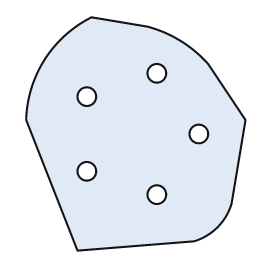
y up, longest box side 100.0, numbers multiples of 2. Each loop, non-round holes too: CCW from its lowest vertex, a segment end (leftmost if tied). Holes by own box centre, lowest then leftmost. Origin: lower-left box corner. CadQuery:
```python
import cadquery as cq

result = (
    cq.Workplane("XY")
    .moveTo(22.0, 0.0)
    .lineTo(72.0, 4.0)
    .threePointArc((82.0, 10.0), (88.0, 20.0))
    .lineTo(94.0, 56.0)
    .lineTo(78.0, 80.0)
    .threePointArc((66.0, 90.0), (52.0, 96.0))
    .lineTo(28.0, 100.0)
    .threePointArc((8.0, 82.0), (0.0, 56.0))
    .close()
    .moveTo(56.0, 24.0)
    .circle(4.0)
    .moveTo(26.0, 34.0)
    .circle(4.0)
    .moveTo(74.0, 50.0)
    .circle(4.0)
    .moveTo(26.0, 66.0)
    .circle(4.0)
    .moveTo(56.0, 76.0)
    .circle(4.0)
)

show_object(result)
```